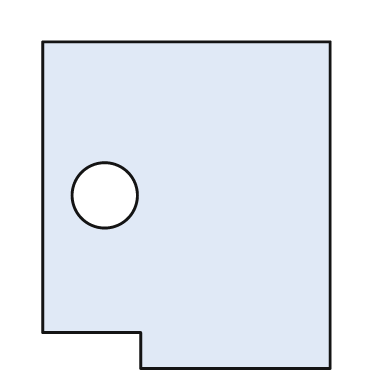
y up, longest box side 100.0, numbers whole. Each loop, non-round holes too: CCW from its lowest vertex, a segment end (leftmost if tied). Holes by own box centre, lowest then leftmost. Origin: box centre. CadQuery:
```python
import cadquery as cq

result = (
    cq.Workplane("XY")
    .moveTo(-14.0, -50.0)
    .lineTo(44.0, -50.0)
    .lineTo(44.0, 50.0)
    .lineTo(-44.0, 50.0)
    .lineTo(-44.0, -39.0)
    .lineTo(-14.0, -39.0)
    .close()
    .moveTo(-25.0, 3.0)
    .circle(10.0)
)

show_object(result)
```